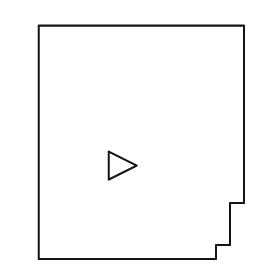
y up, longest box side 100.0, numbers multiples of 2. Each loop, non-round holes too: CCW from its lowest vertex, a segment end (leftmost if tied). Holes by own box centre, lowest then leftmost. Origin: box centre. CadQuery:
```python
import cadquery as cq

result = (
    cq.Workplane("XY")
    .moveTo(-44.0, -50.0)
    .lineTo(32.0, -50.0)
    .lineTo(32.0, -44.0)
    .lineTo(38.0, -44.0)
    .lineTo(38.0, -26.0)
    .lineTo(44.0, -26.0)
    .lineTo(44.0, 50.0)
    .lineTo(-44.0, 50.0)
    .close()
    .moveTo(-14.0, -16.0)
    .lineTo(-2.0, -10.0)
    .lineTo(-14.0, -4.0)
    .close()
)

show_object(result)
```